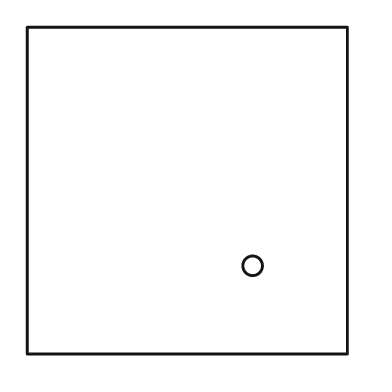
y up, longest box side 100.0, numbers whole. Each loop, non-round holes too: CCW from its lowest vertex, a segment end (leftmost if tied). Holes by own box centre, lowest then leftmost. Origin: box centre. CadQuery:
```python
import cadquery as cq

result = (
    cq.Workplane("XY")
    .moveTo(-49.0, -50.0)
    .lineTo(49.0, -50.0)
    .lineTo(49.0, 50.0)
    .lineTo(-49.0, 50.0)
    .close()
    .moveTo(20.0, -23.0)
    .circle(3.0)
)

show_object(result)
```